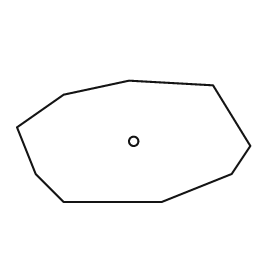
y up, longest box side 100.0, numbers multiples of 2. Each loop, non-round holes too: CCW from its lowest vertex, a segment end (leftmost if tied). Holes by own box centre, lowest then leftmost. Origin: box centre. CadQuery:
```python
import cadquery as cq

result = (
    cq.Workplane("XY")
    .moveTo(-30.0, -26.0)
    .lineTo(12.0, -26.0)
    .lineTo(42.0, -14.0)
    .lineTo(50.0, -2.0)
    .lineTo(34.0, 24.0)
    .lineTo(-2.0, 26.0)
    .lineTo(-30.0, 20.0)
    .lineTo(-50.0, 6.0)
    .lineTo(-42.0, -14.0)
    .close()
    .moveTo(0.0, 0.0)
    .circle(2.0)
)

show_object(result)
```